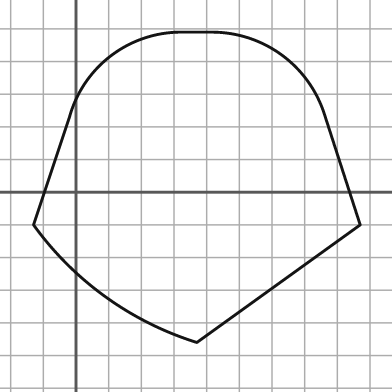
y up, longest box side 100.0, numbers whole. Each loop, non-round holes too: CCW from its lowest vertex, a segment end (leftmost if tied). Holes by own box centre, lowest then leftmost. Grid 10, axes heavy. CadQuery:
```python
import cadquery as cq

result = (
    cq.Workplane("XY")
    .moveTo(37.0, -46.0)
    .lineTo(87.0, -10.0)
    .lineTo(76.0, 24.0)
    .threePointArc((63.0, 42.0), (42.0, 49.0))
    .lineTo(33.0, 49.0)
    .threePointArc((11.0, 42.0), (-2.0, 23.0))
    .lineTo(-13.0, -10.0)
    .threePointArc((9.0, -32.0), (37.0, -46.0))
    .close()
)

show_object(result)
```